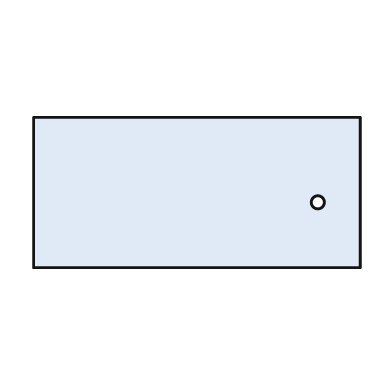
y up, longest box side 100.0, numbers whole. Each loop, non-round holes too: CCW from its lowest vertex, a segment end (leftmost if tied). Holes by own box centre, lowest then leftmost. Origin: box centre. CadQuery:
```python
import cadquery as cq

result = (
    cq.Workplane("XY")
    .moveTo(-50.0, -23.0)
    .lineTo(50.0, -23.0)
    .lineTo(50.0, 23.0)
    .lineTo(-50.0, 23.0)
    .close()
    .moveTo(37.0, -3.0)
    .circle(2.0)
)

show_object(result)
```